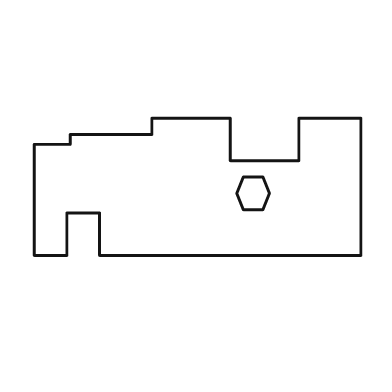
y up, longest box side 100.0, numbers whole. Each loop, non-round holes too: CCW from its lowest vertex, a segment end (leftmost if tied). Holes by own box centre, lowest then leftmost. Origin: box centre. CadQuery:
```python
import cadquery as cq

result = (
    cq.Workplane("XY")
    .moveTo(-50.0, -21.0)
    .lineTo(-40.0, -21.0)
    .lineTo(-40.0, -8.0)
    .lineTo(-30.0, -8.0)
    .lineTo(-30.0, -21.0)
    .lineTo(50.0, -21.0)
    .lineTo(50.0, 21.0)
    .lineTo(31.0, 21.0)
    .lineTo(31.0, 8.0)
    .lineTo(10.0, 8.0)
    .lineTo(10.0, 21.0)
    .lineTo(-14.0, 21.0)
    .lineTo(-14.0, 16.0)
    .lineTo(-39.0, 16.0)
    .lineTo(-39.0, 13.0)
    .lineTo(-50.0, 13.0)
    .close()
    .moveTo(14.0, -7.0)
    .lineTo(20.0, -7.0)
    .lineTo(22.0, -2.0)
    .lineTo(20.0, 3.0)
    .lineTo(14.0, 3.0)
    .lineTo(12.0, -2.0)
    .close()
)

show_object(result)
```